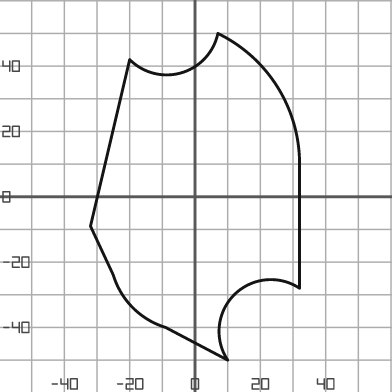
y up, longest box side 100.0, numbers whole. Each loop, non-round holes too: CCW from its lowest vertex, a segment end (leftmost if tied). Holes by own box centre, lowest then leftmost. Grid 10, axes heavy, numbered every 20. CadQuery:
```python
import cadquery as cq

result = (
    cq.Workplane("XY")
    .moveTo(10.0, -50.0)
    .threePointArc((12.0, -30.0), (32.0, -28.0))
    .lineTo(32.0, 11.0)
    .threePointArc((25.0, 34.0), (7.0, 50.0))
    .threePointArc((-4.0, 38.0), (-20.0, 42.0))
    .lineTo(-32.0, -9.0)
    .lineTo(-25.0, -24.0)
    .threePointArc((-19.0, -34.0), (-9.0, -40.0))
    .close()
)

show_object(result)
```